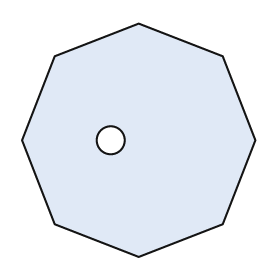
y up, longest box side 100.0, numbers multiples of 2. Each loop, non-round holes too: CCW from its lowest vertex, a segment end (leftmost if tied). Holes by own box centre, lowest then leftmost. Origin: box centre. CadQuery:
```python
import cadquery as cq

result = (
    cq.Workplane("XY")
    .moveTo(0.0, -50.0)
    .lineTo(36.0, -36.0)
    .lineTo(50.0, 0.0)
    .lineTo(36.0, 36.0)
    .lineTo(0.0, 50.0)
    .lineTo(-36.0, 36.0)
    .lineTo(-50.0, 0.0)
    .lineTo(-36.0, -36.0)
    .close()
    .moveTo(-12.0, 0.0)
    .circle(6.0)
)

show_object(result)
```